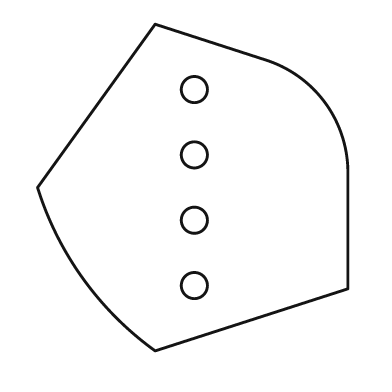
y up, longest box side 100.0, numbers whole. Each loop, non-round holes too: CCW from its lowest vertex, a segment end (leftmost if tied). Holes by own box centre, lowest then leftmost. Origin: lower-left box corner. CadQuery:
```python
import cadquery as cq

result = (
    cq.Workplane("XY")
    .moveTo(36.0, 0.0)
    .lineTo(95.0, 19.0)
    .lineTo(95.0, 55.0)
    .threePointArc((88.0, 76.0), (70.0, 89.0))
    .lineTo(36.0, 100.0)
    .lineTo(0.0, 50.0)
    .threePointArc((14.0, 22.0), (36.0, 0.0))
    .close()
    .moveTo(48.0, 20.0)
    .circle(4.0)
    .moveTo(48.0, 40.0)
    .circle(4.0)
    .moveTo(48.0, 60.0)
    .circle(4.0)
    .moveTo(48.0, 80.0)
    .circle(4.0)
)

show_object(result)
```